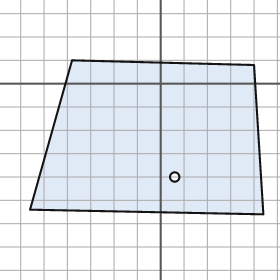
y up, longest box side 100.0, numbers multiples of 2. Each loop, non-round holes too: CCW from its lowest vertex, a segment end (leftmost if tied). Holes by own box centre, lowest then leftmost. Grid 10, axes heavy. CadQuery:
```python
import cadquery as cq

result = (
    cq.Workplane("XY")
    .moveTo(44.0, -56.0)
    .lineTo(40.0, 8.0)
    .lineTo(-38.0, 10.0)
    .lineTo(-56.0, -54.0)
    .close()
    .moveTo(6.0, -40.0)
    .circle(2.0)
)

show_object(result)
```